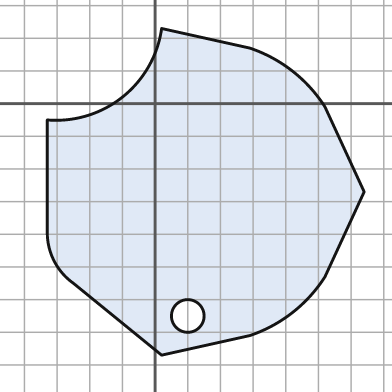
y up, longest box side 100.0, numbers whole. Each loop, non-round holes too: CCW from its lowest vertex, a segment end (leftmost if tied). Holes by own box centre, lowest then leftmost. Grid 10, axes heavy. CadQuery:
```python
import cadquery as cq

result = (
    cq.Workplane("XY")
    .moveTo(2.0, -77.0)
    .lineTo(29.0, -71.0)
    .threePointArc((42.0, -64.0), (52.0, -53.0))
    .lineTo(64.0, -27.0)
    .lineTo(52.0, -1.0)
    .threePointArc((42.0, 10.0), (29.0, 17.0))
    .lineTo(2.0, 23.0)
    .threePointArc((-10.0, 2.0), (-33.0, -5.0))
    .lineTo(-33.0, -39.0)
    .threePointArc((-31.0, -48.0), (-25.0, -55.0))
    .close()
    .moveTo(10.0, -65.0)
    .circle(5.0)
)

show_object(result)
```